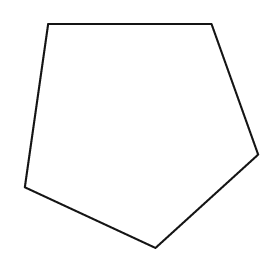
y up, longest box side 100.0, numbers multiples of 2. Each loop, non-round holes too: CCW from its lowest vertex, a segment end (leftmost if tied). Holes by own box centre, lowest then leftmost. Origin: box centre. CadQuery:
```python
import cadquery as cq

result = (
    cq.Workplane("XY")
    .moveTo(6.0, -48.0)
    .lineTo(50.0, -8.0)
    .lineTo(30.0, 48.0)
    .lineTo(-40.0, 48.0)
    .lineTo(-50.0, -22.0)
    .close()
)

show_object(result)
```